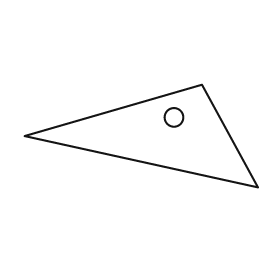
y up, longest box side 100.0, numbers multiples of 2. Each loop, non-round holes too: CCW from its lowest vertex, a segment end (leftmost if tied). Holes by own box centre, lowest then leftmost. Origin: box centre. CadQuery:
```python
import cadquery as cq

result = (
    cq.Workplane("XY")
    .moveTo(50.0, -22.0)
    .lineTo(26.0, 22.0)
    .lineTo(-50.0, 0.0)
    .close()
    .moveTo(14.0, 8.0)
    .circle(4.0)
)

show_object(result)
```